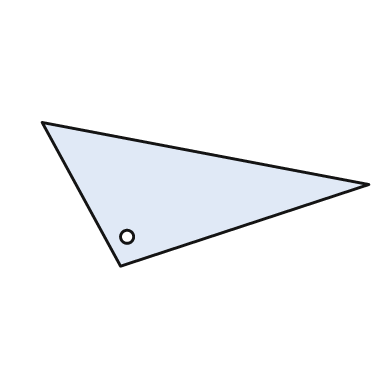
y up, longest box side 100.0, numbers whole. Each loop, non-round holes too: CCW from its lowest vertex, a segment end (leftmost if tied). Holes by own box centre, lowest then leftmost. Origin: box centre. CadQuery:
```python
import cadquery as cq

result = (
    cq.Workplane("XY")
    .moveTo(-26.0, -22.0)
    .lineTo(50.0, 3.0)
    .lineTo(-50.0, 22.0)
    .close()
    .moveTo(-24.0, -13.0)
    .circle(2.0)
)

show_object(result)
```